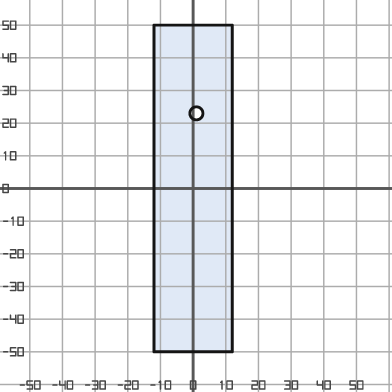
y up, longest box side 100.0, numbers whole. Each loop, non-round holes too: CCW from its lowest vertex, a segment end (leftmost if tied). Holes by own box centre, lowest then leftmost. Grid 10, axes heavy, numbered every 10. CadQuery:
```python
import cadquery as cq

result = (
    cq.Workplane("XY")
    .moveTo(-12.0, -50.0)
    .lineTo(12.0, -50.0)
    .lineTo(12.0, 50.0)
    .lineTo(-12.0, 50.0)
    .close()
    .moveTo(1.0, 23.0)
    .circle(2.0)
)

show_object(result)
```